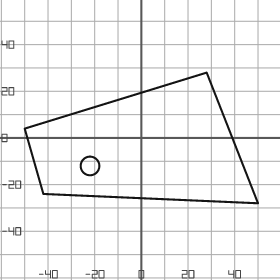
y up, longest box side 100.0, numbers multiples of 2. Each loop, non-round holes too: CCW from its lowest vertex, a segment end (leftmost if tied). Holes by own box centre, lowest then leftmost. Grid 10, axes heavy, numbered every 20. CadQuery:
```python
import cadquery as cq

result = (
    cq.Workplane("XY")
    .moveTo(50.0, -28.0)
    .lineTo(28.0, 28.0)
    .lineTo(-50.0, 4.0)
    .lineTo(-42.0, -24.0)
    .close()
    .moveTo(-22.0, -12.0)
    .circle(4.0)
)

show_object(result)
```